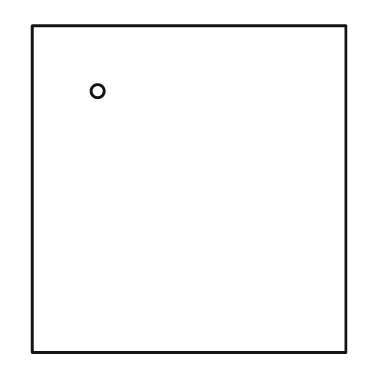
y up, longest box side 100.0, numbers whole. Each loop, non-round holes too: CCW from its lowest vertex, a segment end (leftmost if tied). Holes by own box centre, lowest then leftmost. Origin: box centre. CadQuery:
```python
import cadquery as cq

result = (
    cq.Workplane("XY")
    .moveTo(-48.0, -50.0)
    .lineTo(48.0, -50.0)
    .lineTo(48.0, 50.0)
    .lineTo(-48.0, 50.0)
    .close()
    .moveTo(-28.0, 30.0)
    .circle(2.0)
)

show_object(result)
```